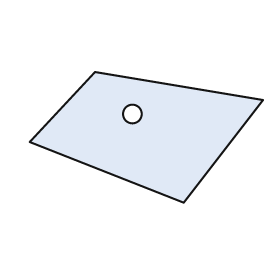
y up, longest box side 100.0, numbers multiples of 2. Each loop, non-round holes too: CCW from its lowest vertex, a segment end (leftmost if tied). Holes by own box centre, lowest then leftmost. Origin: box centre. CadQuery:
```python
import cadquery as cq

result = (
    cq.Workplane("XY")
    .moveTo(16.0, -28.0)
    .lineTo(50.0, 16.0)
    .lineTo(-22.0, 28.0)
    .lineTo(-50.0, -2.0)
    .close()
    .moveTo(-6.0, 10.0)
    .circle(4.0)
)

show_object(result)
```